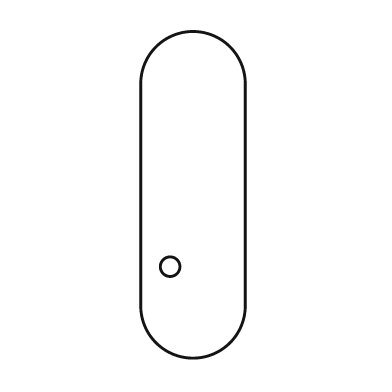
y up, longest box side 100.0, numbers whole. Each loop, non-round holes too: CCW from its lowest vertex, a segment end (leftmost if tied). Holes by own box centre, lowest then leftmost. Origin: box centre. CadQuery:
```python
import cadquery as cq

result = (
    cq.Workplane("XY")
    .moveTo(-16.0, -34.0)
    .threePointArc((0.0, -50.0), (16.0, -34.0))
    .lineTo(16.0, 34.0)
    .threePointArc((0.0, 50.0), (-16.0, 34.0))
    .close()
    .moveTo(-7.0, -22.0)
    .circle(3.0)
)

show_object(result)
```